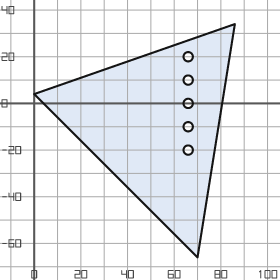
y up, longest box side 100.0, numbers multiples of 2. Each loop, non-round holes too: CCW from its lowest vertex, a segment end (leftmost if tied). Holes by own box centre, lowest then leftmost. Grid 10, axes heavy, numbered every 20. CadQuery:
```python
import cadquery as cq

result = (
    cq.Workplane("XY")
    .moveTo(70.0, -66.0)
    .lineTo(86.0, 34.0)
    .lineTo(0.0, 4.0)
    .close()
    .moveTo(66.0, -20.0)
    .circle(2.0)
    .moveTo(66.0, -10.0)
    .circle(2.0)
    .moveTo(66.0, 0.0)
    .circle(2.0)
    .moveTo(66.0, 10.0)
    .circle(2.0)
    .moveTo(66.0, 20.0)
    .circle(2.0)
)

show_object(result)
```